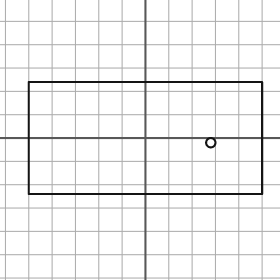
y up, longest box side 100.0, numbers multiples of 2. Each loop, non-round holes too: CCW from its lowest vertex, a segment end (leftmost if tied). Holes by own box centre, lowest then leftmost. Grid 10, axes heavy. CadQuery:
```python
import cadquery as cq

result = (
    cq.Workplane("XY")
    .moveTo(-50.0, -24.0)
    .lineTo(50.0, -24.0)
    .lineTo(50.0, 24.0)
    .lineTo(-50.0, 24.0)
    .close()
    .moveTo(28.0, -2.0)
    .circle(2.0)
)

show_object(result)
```